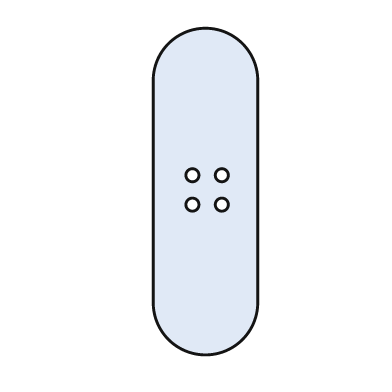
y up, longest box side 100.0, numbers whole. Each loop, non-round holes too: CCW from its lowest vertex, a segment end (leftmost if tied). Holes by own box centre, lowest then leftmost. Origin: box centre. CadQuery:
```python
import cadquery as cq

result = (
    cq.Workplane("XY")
    .moveTo(-16.0, -34.0)
    .threePointArc((0.0, -50.0), (16.0, -34.0))
    .lineTo(16.0, 34.0)
    .threePointArc((0.0, 50.0), (-16.0, 34.0))
    .close()
    .moveTo(-4.0, -4.0)
    .circle(2.0)
    .moveTo(5.0, -4.0)
    .circle(2.0)
    .moveTo(-4.0, 5.0)
    .circle(2.0)
    .moveTo(5.0, 5.0)
    .circle(2.0)
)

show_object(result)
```